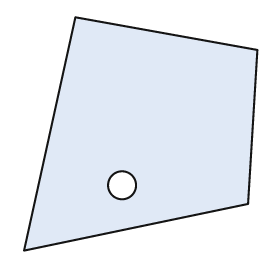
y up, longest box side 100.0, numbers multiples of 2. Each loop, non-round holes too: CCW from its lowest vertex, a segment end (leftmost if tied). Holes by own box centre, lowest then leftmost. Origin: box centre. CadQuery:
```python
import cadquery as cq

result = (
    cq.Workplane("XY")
    .moveTo(-50.0, -50.0)
    .lineTo(46.0, -30.0)
    .lineTo(50.0, 36.0)
    .lineTo(-28.0, 50.0)
    .close()
    .moveTo(-8.0, -22.0)
    .circle(6.0)
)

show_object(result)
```